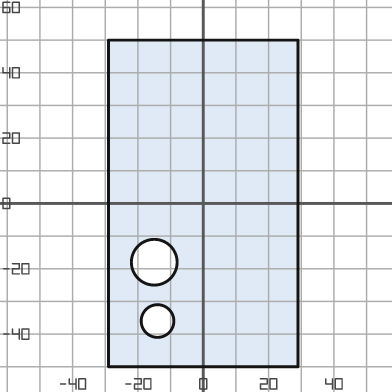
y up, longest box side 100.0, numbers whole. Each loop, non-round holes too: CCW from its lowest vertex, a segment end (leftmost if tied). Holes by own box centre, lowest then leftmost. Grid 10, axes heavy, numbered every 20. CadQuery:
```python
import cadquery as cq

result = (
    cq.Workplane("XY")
    .moveTo(-29.0, -50.0)
    .lineTo(29.0, -50.0)
    .lineTo(29.0, 50.0)
    .lineTo(-29.0, 50.0)
    .close()
    .moveTo(-14.0, -36.0)
    .circle(5.0)
    .moveTo(-15.0, -18.0)
    .circle(7.0)
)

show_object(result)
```